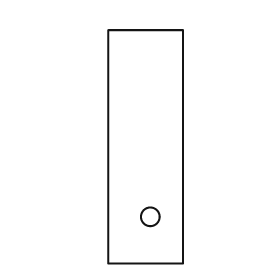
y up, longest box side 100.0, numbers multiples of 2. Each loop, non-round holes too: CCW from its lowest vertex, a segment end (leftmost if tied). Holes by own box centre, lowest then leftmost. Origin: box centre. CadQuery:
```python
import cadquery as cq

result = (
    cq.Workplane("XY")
    .moveTo(-16.0, -50.0)
    .lineTo(16.0, -50.0)
    .lineTo(16.0, 50.0)
    .lineTo(-16.0, 50.0)
    .close()
    .moveTo(2.0, -30.0)
    .circle(4.0)
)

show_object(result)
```